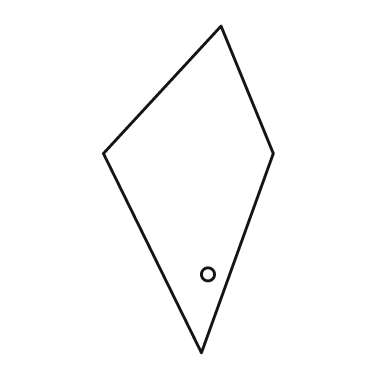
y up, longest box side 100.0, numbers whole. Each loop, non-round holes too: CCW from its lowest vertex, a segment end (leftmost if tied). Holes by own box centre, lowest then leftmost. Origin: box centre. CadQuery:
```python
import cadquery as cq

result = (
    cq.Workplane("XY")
    .moveTo(4.0, -50.0)
    .lineTo(26.0, 11.0)
    .lineTo(10.0, 50.0)
    .lineTo(-26.0, 11.0)
    .close()
    .moveTo(6.0, -26.0)
    .circle(2.0)
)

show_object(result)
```